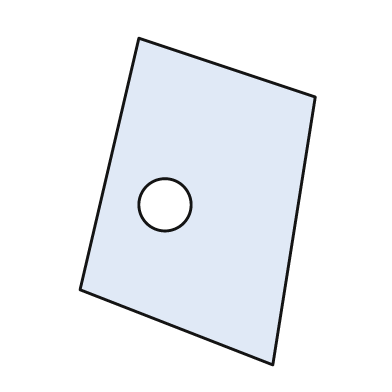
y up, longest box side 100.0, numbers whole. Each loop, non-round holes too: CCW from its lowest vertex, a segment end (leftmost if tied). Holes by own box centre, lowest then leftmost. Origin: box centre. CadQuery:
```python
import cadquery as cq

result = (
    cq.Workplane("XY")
    .moveTo(23.0, -50.0)
    .lineTo(36.0, 32.0)
    .lineTo(-18.0, 50.0)
    .lineTo(-36.0, -27.0)
    .close()
    .moveTo(-10.0, -1.0)
    .circle(8.0)
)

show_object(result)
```